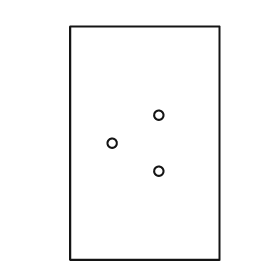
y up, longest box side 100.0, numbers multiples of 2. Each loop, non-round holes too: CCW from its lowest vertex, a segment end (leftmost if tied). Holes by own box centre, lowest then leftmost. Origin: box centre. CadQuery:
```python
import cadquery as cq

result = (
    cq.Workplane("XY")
    .moveTo(-32.0, -50.0)
    .lineTo(32.0, -50.0)
    .lineTo(32.0, 50.0)
    .lineTo(-32.0, 50.0)
    .close()
    .moveTo(6.0, -12.0)
    .circle(2.0)
    .moveTo(-14.0, 0.0)
    .circle(2.0)
    .moveTo(6.0, 12.0)
    .circle(2.0)
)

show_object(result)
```